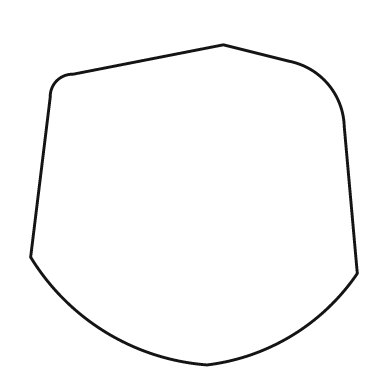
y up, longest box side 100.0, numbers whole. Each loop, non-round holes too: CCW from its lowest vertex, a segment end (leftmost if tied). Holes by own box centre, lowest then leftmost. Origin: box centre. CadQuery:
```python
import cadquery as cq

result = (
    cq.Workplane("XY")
    .moveTo(4.0, -49.0)
    .threePointArc((30.0, -40.0), (50.0, -21.0))
    .lineTo(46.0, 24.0)
    .threePointArc((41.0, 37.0), (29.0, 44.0))
    .lineTo(9.0, 49.0)
    .lineTo(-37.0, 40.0)
    .threePointArc((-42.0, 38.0), (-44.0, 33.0))
    .lineTo(-50.0, -16.0)
    .threePointArc((-27.0, -39.0), (4.0, -49.0))
    .close()
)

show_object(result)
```